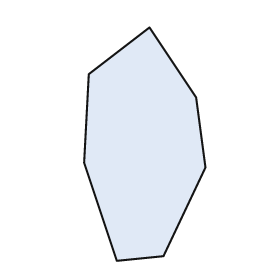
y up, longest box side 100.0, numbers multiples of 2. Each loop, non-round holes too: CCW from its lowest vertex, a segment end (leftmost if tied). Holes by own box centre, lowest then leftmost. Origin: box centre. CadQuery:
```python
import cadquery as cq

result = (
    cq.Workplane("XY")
    .moveTo(-12.0, -50.0)
    .lineTo(8.0, -48.0)
    .lineTo(26.0, -10.0)
    .lineTo(22.0, 20.0)
    .lineTo(2.0, 50.0)
    .lineTo(-24.0, 30.0)
    .lineTo(-26.0, -8.0)
    .close()
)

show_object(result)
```